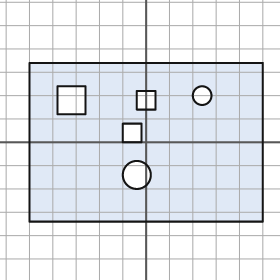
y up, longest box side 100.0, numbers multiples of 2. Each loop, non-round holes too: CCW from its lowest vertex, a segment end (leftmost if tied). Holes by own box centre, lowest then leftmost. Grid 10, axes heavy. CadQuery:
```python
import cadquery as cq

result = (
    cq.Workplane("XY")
    .moveTo(-50.0, -34.0)
    .lineTo(50.0, -34.0)
    .lineTo(50.0, 34.0)
    .lineTo(-50.0, 34.0)
    .close()
    .moveTo(-4.0, -14.0)
    .circle(6.0)
    .moveTo(-10.0, 0.0)
    .lineTo(-2.0, 0.0)
    .lineTo(-2.0, 8.0)
    .lineTo(-10.0, 8.0)
    .close()
    .moveTo(-38.0, 12.0)
    .lineTo(-26.0, 12.0)
    .lineTo(-26.0, 24.0)
    .lineTo(-38.0, 24.0)
    .close()
    .moveTo(-4.0, 14.0)
    .lineTo(4.0, 14.0)
    .lineTo(4.0, 22.0)
    .lineTo(-4.0, 22.0)
    .close()
    .moveTo(24.0, 20.0)
    .circle(4.0)
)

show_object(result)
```